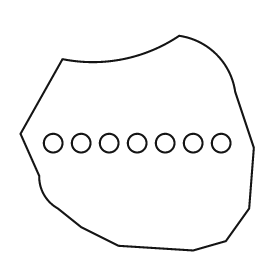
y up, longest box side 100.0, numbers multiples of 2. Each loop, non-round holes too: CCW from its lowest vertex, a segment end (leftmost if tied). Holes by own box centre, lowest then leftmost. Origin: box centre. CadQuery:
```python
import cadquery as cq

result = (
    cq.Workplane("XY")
    .moveTo(24.0, -46.0)
    .lineTo(38.0, -42.0)
    .lineTo(48.0, -28.0)
    .lineTo(50.0, -2.0)
    .lineTo(42.0, 22.0)
    .threePointArc((34.0, 38.0), (18.0, 46.0))
    .threePointArc((-6.0, 36.0), (-32.0, 36.0))
    .lineTo(-50.0, 4.0)
    .lineTo(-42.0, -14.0)
    .threePointArc((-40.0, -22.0), (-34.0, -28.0))
    .lineTo(-24.0, -36.0)
    .lineTo(-8.0, -44.0)
    .close()
    .moveTo(-36.0, 0.0)
    .circle(4.0)
    .moveTo(-24.0, 0.0)
    .circle(4.0)
    .moveTo(-12.0, 0.0)
    .circle(4.0)
    .moveTo(0.0, 0.0)
    .circle(4.0)
    .moveTo(12.0, 0.0)
    .circle(4.0)
    .moveTo(24.0, 0.0)
    .circle(4.0)
    .moveTo(36.0, 0.0)
    .circle(4.0)
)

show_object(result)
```